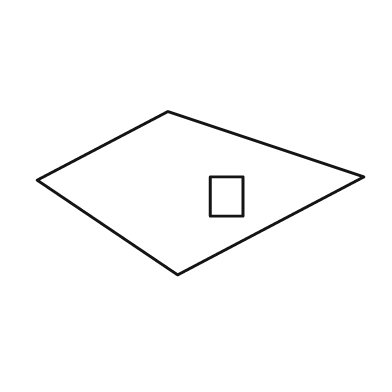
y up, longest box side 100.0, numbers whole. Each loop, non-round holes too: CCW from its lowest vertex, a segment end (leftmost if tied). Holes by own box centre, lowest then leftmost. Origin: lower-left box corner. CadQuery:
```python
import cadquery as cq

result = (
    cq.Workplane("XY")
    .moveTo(43.0, 0.0)
    .lineTo(100.0, 30.0)
    .lineTo(40.0, 50.0)
    .lineTo(0.0, 29.0)
    .close()
    .moveTo(53.0, 18.0)
    .lineTo(63.0, 18.0)
    .lineTo(63.0, 30.0)
    .lineTo(53.0, 30.0)
    .close()
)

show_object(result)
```